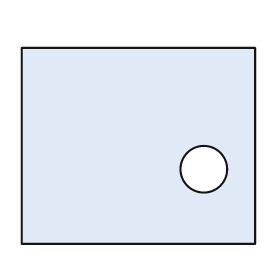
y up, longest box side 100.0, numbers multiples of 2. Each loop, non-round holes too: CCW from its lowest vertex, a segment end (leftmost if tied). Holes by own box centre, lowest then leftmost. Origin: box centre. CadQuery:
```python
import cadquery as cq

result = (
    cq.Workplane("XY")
    .moveTo(-50.0, -42.0)
    .lineTo(50.0, -42.0)
    .lineTo(50.0, 42.0)
    .lineTo(-50.0, 42.0)
    .close()
    .moveTo(28.0, -10.0)
    .circle(10.0)
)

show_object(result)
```